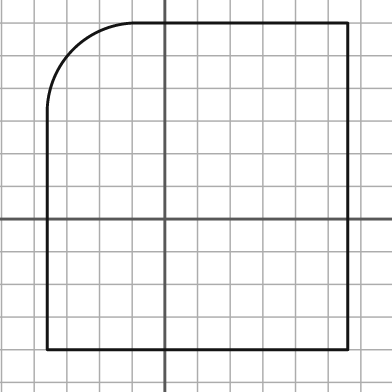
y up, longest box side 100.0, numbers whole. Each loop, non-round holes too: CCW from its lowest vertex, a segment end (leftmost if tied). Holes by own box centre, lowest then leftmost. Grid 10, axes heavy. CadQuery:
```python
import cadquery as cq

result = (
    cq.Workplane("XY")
    .moveTo(-36.0, -40.0)
    .lineTo(56.0, -40.0)
    .lineTo(56.0, 60.0)
    .lineTo(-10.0, 60.0)
    .threePointArc((-28.0, 52.0), (-36.0, 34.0))
    .close()
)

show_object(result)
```